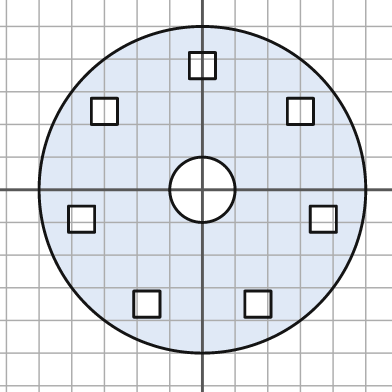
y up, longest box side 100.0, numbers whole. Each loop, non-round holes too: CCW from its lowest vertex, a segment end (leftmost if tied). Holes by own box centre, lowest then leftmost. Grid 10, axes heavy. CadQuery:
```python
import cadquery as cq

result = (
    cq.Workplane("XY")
    .moveTo(0.0, 0.0)
    .circle(50.0)
    .moveTo(-21.0, -39.0)
    .lineTo(-13.0, -39.0)
    .lineTo(-13.0, -31.0)
    .lineTo(-21.0, -31.0)
    .close()
    .moveTo(13.0, -39.0)
    .lineTo(21.0, -39.0)
    .lineTo(21.0, -31.0)
    .lineTo(13.0, -31.0)
    .close()
    .moveTo(-41.0, -13.0)
    .lineTo(-33.0, -13.0)
    .lineTo(-33.0, -5.0)
    .lineTo(-41.0, -5.0)
    .close()
    .moveTo(33.0, -13.0)
    .lineTo(41.0, -13.0)
    .lineTo(41.0, -5.0)
    .lineTo(33.0, -5.0)
    .close()
    .moveTo(0.0, 0.0)
    .circle(10.0)
    .moveTo(-34.0, 20.0)
    .lineTo(-26.0, 20.0)
    .lineTo(-26.0, 28.0)
    .lineTo(-34.0, 28.0)
    .close()
    .moveTo(26.0, 20.0)
    .lineTo(34.0, 20.0)
    .lineTo(34.0, 28.0)
    .lineTo(26.0, 28.0)
    .close()
    .moveTo(-4.0, 34.0)
    .lineTo(4.0, 34.0)
    .lineTo(4.0, 42.0)
    .lineTo(-4.0, 42.0)
    .close()
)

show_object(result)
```